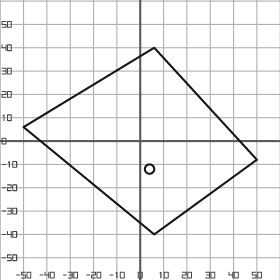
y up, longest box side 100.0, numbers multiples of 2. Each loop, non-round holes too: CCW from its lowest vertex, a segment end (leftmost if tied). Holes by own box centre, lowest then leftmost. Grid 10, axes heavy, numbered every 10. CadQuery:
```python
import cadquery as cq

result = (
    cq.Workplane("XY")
    .moveTo(6.0, -40.0)
    .lineTo(50.0, -8.0)
    .lineTo(6.0, 40.0)
    .lineTo(-50.0, 6.0)
    .close()
    .moveTo(4.0, -12.0)
    .circle(2.0)
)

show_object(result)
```